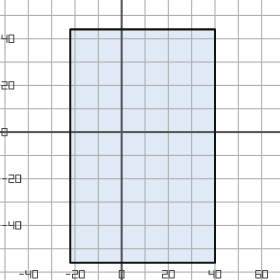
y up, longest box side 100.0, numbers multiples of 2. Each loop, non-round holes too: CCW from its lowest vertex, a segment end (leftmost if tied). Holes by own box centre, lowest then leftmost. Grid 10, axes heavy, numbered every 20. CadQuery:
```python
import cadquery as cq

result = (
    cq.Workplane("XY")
    .moveTo(-22.0, -56.0)
    .lineTo(40.0, -56.0)
    .lineTo(40.0, 44.0)
    .lineTo(-22.0, 44.0)
    .close()
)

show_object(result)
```